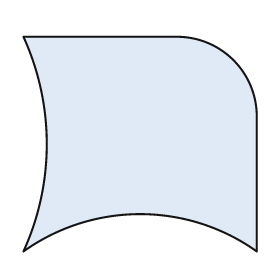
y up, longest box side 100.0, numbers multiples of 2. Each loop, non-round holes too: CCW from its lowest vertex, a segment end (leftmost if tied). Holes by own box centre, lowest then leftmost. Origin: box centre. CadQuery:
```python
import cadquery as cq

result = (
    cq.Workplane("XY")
    .moveTo(-50.0, -46.0)
    .threePointArc((0.0, -30.0), (50.0, -46.0))
    .lineTo(50.0, 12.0)
    .threePointArc((40.0, 36.0), (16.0, 46.0))
    .lineTo(-50.0, 46.0)
    .threePointArc((-40.0, 0.0), (-50.0, -46.0))
    .close()
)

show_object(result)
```